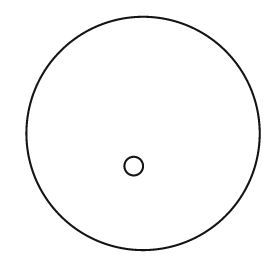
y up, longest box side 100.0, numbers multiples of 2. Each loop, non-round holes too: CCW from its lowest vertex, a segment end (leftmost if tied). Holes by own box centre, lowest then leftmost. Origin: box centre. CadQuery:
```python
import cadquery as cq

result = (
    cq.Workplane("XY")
    .moveTo(0.0, 0.0)
    .circle(50.0)
    .moveTo(-4.0, -14.0)
    .circle(4.0)
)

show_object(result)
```